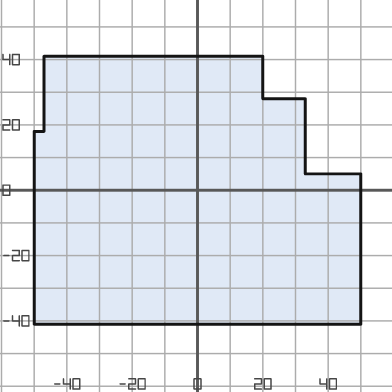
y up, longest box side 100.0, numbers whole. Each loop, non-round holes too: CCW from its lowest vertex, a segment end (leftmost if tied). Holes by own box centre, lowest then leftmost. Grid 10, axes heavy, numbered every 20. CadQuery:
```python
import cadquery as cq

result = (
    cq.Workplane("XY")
    .moveTo(-50.0, -41.0)
    .lineTo(50.0, -41.0)
    .lineTo(50.0, 5.0)
    .lineTo(33.0, 5.0)
    .lineTo(33.0, 28.0)
    .lineTo(20.0, 28.0)
    .lineTo(20.0, 41.0)
    .lineTo(-47.0, 41.0)
    .lineTo(-47.0, 18.0)
    .lineTo(-50.0, 18.0)
    .close()
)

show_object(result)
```